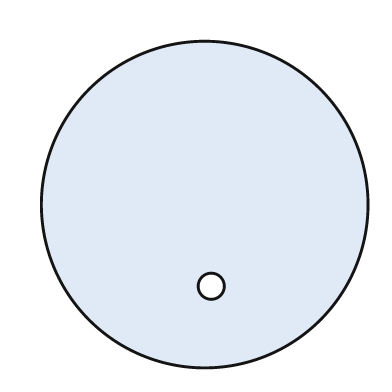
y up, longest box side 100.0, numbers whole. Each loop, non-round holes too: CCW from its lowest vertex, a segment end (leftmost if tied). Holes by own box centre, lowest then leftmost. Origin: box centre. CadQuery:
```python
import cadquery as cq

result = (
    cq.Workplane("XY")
    .moveTo(0.0, 0.0)
    .circle(50.0)
    .moveTo(2.0, -25.0)
    .circle(4.0)
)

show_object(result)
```